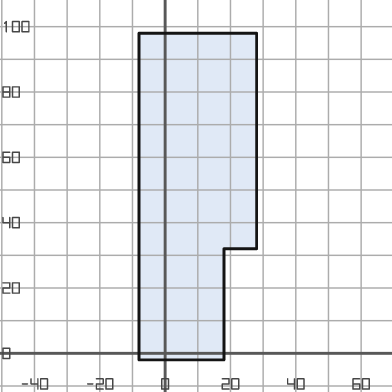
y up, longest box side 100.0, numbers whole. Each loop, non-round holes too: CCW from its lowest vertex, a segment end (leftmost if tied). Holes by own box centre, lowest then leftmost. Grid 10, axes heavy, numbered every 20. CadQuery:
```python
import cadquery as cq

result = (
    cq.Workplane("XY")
    .moveTo(-8.0, -2.0)
    .lineTo(18.0, -2.0)
    .lineTo(18.0, 32.0)
    .lineTo(28.0, 32.0)
    .lineTo(28.0, 98.0)
    .lineTo(-8.0, 98.0)
    .close()
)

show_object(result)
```